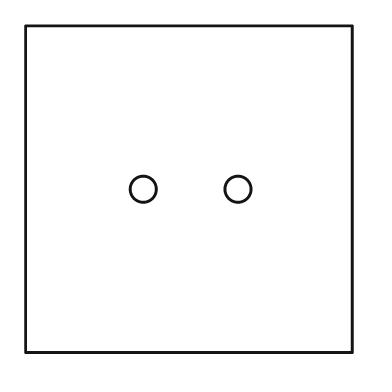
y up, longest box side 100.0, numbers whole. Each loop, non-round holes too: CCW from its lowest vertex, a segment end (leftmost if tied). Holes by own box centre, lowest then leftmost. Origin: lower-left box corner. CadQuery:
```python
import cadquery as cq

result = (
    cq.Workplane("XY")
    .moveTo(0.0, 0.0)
    .lineTo(100.0, 0.0)
    .lineTo(100.0, 100.0)
    .lineTo(0.0, 100.0)
    .close()
    .moveTo(36.0, 50.0)
    .circle(4.0)
    .moveTo(65.0, 50.0)
    .circle(4.0)
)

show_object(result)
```